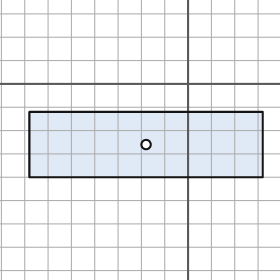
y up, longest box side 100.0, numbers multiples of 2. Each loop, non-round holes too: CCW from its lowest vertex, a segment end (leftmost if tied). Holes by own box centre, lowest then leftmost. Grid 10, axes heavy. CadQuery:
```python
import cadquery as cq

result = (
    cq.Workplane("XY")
    .moveTo(-68.0, -40.0)
    .lineTo(32.0, -40.0)
    .lineTo(32.0, -12.0)
    .lineTo(-68.0, -12.0)
    .close()
    .moveTo(-18.0, -26.0)
    .circle(2.0)
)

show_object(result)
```